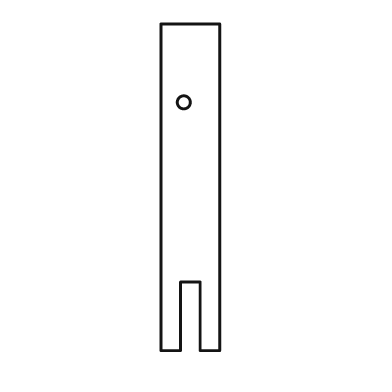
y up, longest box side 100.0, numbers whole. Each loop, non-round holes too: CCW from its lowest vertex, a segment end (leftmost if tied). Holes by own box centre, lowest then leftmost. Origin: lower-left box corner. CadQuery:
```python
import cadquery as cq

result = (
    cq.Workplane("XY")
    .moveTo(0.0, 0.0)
    .lineTo(6.0, 0.0)
    .lineTo(6.0, 21.0)
    .lineTo(12.0, 21.0)
    .lineTo(12.0, 0.0)
    .lineTo(18.0, 0.0)
    .lineTo(18.0, 100.0)
    .lineTo(0.0, 100.0)
    .close()
    .moveTo(7.0, 76.0)
    .circle(2.0)
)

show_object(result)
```